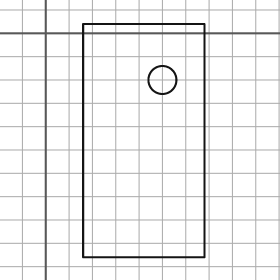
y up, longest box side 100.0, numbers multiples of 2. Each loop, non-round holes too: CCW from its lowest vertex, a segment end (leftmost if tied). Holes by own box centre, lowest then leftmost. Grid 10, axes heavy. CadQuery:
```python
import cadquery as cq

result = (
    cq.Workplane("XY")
    .moveTo(16.0, -96.0)
    .lineTo(68.0, -96.0)
    .lineTo(68.0, 4.0)
    .lineTo(16.0, 4.0)
    .close()
    .moveTo(50.0, -20.0)
    .circle(6.0)
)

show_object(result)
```